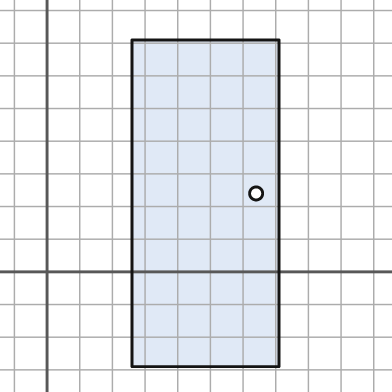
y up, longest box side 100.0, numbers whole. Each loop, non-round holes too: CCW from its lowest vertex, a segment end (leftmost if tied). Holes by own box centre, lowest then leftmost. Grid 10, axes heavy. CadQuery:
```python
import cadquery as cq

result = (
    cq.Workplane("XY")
    .moveTo(26.0, -29.0)
    .lineTo(71.0, -29.0)
    .lineTo(71.0, 71.0)
    .lineTo(26.0, 71.0)
    .close()
    .moveTo(64.0, 24.0)
    .circle(2.0)
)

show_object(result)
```